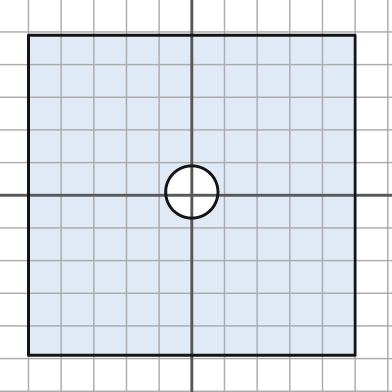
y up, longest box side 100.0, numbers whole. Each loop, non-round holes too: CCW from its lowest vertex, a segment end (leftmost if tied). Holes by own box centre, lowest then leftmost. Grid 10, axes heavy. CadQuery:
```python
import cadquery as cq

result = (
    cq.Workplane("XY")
    .moveTo(-50.0, -49.0)
    .lineTo(50.0, -49.0)
    .lineTo(50.0, 49.0)
    .lineTo(-50.0, 49.0)
    .close()
    .moveTo(0.0, 1.0)
    .circle(8.0)
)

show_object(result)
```